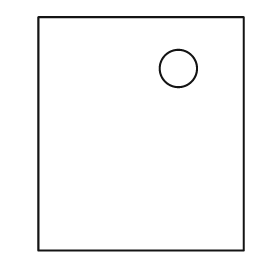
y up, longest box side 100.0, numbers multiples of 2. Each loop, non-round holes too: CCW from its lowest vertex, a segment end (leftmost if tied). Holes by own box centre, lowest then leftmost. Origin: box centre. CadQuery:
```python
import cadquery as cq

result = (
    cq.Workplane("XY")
    .moveTo(-44.0, -50.0)
    .lineTo(44.0, -50.0)
    .lineTo(44.0, 50.0)
    .lineTo(-44.0, 50.0)
    .close()
    .moveTo(16.0, 28.0)
    .circle(8.0)
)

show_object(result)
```